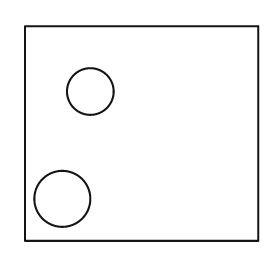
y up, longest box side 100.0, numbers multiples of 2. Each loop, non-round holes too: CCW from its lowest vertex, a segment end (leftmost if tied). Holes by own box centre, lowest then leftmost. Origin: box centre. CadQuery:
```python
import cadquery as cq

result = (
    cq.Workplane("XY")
    .moveTo(-50.0, -46.0)
    .lineTo(50.0, -46.0)
    .lineTo(50.0, 46.0)
    .lineTo(-50.0, 46.0)
    .close()
    .moveTo(-34.0, -28.0)
    .circle(12.0)
    .moveTo(-22.0, 18.0)
    .circle(10.0)
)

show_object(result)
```